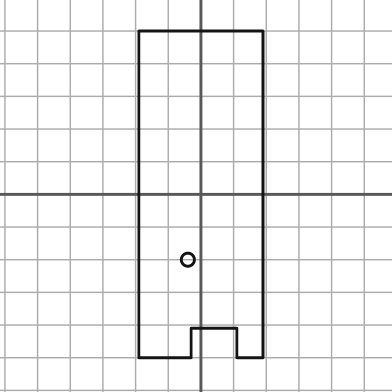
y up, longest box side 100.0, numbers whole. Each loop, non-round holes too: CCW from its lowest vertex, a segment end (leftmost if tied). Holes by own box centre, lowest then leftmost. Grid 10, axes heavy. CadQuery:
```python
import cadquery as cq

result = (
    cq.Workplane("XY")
    .moveTo(-19.0, -50.0)
    .lineTo(-3.0, -50.0)
    .lineTo(-3.0, -41.0)
    .lineTo(11.0, -41.0)
    .lineTo(11.0, -50.0)
    .lineTo(19.0, -50.0)
    .lineTo(19.0, 50.0)
    .lineTo(-19.0, 50.0)
    .close()
    .moveTo(-4.0, -20.0)
    .circle(2.0)
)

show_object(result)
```